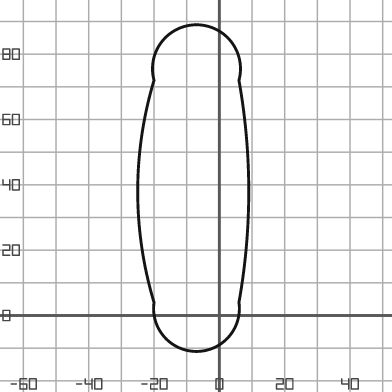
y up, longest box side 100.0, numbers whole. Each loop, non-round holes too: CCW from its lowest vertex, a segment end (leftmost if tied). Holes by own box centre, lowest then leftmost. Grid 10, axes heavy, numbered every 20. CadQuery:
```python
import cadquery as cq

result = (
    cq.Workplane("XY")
    .moveTo(-20.0, 4.0)
    .threePointArc((-7.0, -11.0), (6.0, 4.0))
    .threePointArc((9.0, 38.0), (6.0, 72.0))
    .threePointArc((-7.0, 89.0), (-20.0, 72.0))
    .threePointArc((-25.0, 38.0), (-20.0, 4.0))
    .close()
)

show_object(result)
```